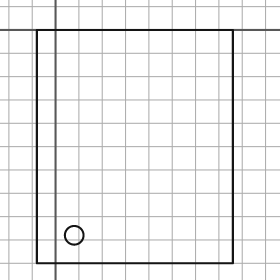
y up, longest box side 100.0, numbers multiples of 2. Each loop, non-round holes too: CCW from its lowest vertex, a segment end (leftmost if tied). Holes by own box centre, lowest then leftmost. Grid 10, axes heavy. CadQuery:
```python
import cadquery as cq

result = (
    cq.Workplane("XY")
    .moveTo(-8.0, -100.0)
    .lineTo(76.0, -100.0)
    .lineTo(76.0, 0.0)
    .lineTo(-8.0, 0.0)
    .close()
    .moveTo(8.0, -88.0)
    .circle(4.0)
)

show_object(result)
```